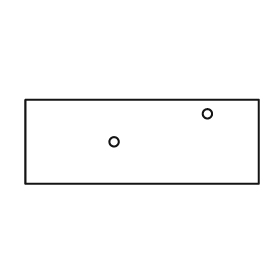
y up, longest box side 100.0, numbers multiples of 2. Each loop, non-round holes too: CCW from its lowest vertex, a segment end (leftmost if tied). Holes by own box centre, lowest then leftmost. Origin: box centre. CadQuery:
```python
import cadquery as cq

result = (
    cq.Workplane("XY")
    .moveTo(-50.0, -18.0)
    .lineTo(50.0, -18.0)
    .lineTo(50.0, 18.0)
    .lineTo(-50.0, 18.0)
    .close()
    .moveTo(-12.0, 0.0)
    .circle(2.0)
    .moveTo(28.0, 12.0)
    .circle(2.0)
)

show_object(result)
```